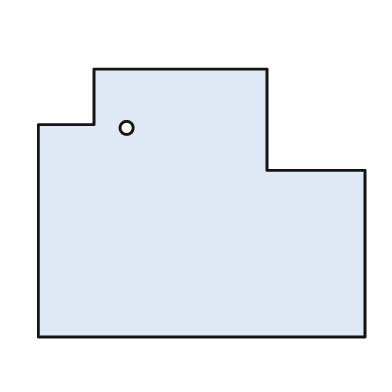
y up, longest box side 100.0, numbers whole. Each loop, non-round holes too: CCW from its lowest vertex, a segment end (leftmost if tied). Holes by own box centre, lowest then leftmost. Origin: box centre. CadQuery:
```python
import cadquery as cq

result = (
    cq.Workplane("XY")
    .moveTo(-50.0, -41.0)
    .lineTo(50.0, -41.0)
    .lineTo(50.0, 10.0)
    .lineTo(20.0, 10.0)
    .lineTo(20.0, 41.0)
    .lineTo(-33.0, 41.0)
    .lineTo(-33.0, 24.0)
    .lineTo(-50.0, 24.0)
    .close()
    .moveTo(-23.0, 23.0)
    .circle(2.0)
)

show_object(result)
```